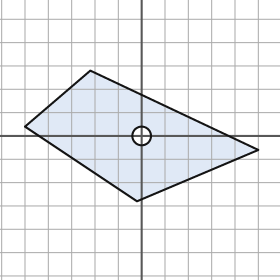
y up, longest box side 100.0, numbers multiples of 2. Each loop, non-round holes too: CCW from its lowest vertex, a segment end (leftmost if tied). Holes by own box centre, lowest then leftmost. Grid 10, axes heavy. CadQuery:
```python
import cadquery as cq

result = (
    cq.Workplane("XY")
    .moveTo(-2.0, -28.0)
    .lineTo(50.0, -6.0)
    .lineTo(-22.0, 28.0)
    .lineTo(-50.0, 4.0)
    .close()
    .moveTo(0.0, 0.0)
    .circle(4.0)
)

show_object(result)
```